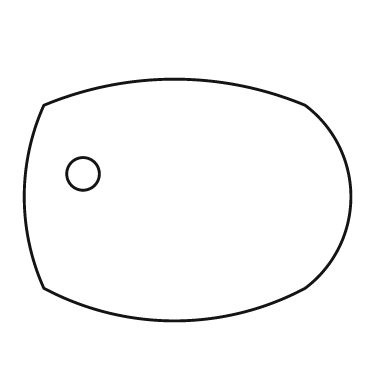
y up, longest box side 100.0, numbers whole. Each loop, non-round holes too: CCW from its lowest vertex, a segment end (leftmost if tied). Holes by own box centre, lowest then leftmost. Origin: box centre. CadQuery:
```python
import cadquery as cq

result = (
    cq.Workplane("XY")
    .moveTo(-44.0, -27.0)
    .threePointArc((-4.0, -37.0), (36.0, -27.0))
    .threePointArc((50.0, 1.0), (36.0, 29.0))
    .threePointArc((-4.0, 37.0), (-44.0, 29.0))
    .threePointArc((-50.0, 1.0), (-44.0, -27.0))
    .close()
    .moveTo(-32.0, 8.0)
    .circle(5.0)
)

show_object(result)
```